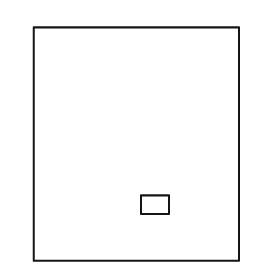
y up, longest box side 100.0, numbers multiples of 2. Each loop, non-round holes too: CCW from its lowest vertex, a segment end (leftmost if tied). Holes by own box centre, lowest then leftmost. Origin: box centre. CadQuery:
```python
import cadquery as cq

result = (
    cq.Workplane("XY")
    .moveTo(-44.0, -50.0)
    .lineTo(44.0, -50.0)
    .lineTo(44.0, 50.0)
    .lineTo(-44.0, 50.0)
    .close()
    .moveTo(2.0, -30.0)
    .lineTo(14.0, -30.0)
    .lineTo(14.0, -22.0)
    .lineTo(2.0, -22.0)
    .close()
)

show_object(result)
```